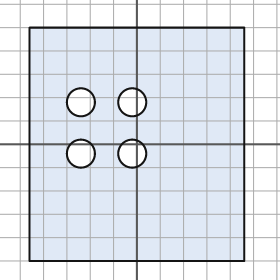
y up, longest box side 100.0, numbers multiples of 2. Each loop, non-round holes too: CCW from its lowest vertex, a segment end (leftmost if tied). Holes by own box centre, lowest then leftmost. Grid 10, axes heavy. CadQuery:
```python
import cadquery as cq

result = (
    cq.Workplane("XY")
    .moveTo(-46.0, -50.0)
    .lineTo(46.0, -50.0)
    .lineTo(46.0, 50.0)
    .lineTo(-46.0, 50.0)
    .close()
    .moveTo(-24.0, -4.0)
    .circle(6.0)
    .moveTo(-2.0, -4.0)
    .circle(6.0)
    .moveTo(-24.0, 18.0)
    .circle(6.0)
    .moveTo(-2.0, 18.0)
    .circle(6.0)
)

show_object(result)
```